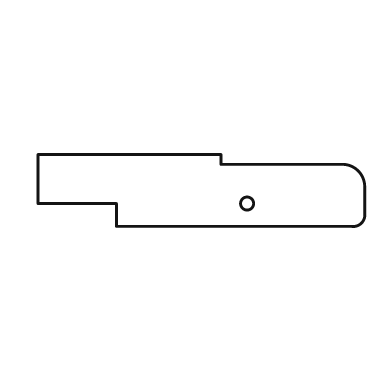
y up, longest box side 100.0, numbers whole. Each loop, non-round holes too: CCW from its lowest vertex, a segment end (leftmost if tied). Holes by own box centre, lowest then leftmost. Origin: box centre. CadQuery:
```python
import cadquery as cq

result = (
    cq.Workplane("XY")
    .moveTo(-26.0, -11.0)
    .lineTo(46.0, -11.0)
    .threePointArc((49.0, -10.0), (50.0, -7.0))
    .lineTo(50.0, 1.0)
    .threePointArc((48.0, 6.0), (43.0, 8.0))
    .lineTo(6.0, 8.0)
    .lineTo(6.0, 11.0)
    .lineTo(-50.0, 11.0)
    .lineTo(-50.0, -4.0)
    .lineTo(-26.0, -4.0)
    .close()
    .moveTo(14.0, -4.0)
    .circle(2.0)
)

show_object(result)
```